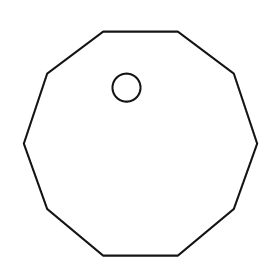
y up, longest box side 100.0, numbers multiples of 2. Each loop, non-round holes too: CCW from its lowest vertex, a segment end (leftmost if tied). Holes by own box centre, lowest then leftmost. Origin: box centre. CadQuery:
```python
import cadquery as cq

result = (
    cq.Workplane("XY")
    .moveTo(-16.0, -48.0)
    .lineTo(16.0, -48.0)
    .lineTo(40.0, -28.0)
    .lineTo(50.0, 0.0)
    .lineTo(40.0, 30.0)
    .lineTo(16.0, 48.0)
    .lineTo(-16.0, 48.0)
    .lineTo(-40.0, 30.0)
    .lineTo(-50.0, 0.0)
    .lineTo(-40.0, -28.0)
    .close()
    .moveTo(-6.0, 24.0)
    .circle(6.0)
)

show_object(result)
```